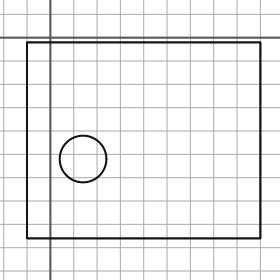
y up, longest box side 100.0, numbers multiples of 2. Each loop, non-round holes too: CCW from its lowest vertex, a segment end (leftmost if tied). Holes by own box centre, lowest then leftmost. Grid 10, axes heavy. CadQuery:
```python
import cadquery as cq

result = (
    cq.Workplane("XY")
    .moveTo(-10.0, -86.0)
    .lineTo(90.0, -86.0)
    .lineTo(90.0, -2.0)
    .lineTo(-10.0, -2.0)
    .close()
    .moveTo(14.0, -52.0)
    .circle(10.0)
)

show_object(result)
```